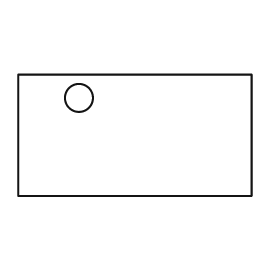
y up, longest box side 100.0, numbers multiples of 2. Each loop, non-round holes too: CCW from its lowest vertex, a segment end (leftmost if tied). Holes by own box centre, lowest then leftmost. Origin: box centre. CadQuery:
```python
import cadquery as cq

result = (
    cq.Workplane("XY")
    .moveTo(-50.0, -26.0)
    .lineTo(50.0, -26.0)
    .lineTo(50.0, 26.0)
    .lineTo(-50.0, 26.0)
    .close()
    .moveTo(-24.0, 16.0)
    .circle(6.0)
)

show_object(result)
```